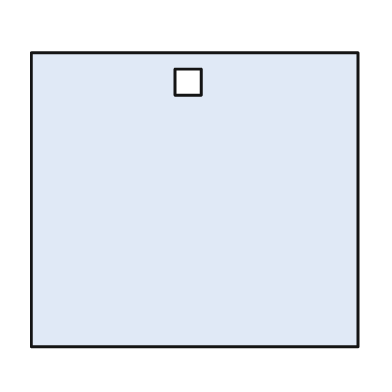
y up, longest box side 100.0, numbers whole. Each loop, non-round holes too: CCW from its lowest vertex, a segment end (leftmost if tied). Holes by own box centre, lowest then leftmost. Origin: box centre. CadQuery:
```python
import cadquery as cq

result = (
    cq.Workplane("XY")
    .moveTo(-50.0, -45.0)
    .lineTo(50.0, -45.0)
    .lineTo(50.0, 45.0)
    .lineTo(-50.0, 45.0)
    .close()
    .moveTo(-6.0, 32.0)
    .lineTo(2.0, 32.0)
    .lineTo(2.0, 40.0)
    .lineTo(-6.0, 40.0)
    .close()
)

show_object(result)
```